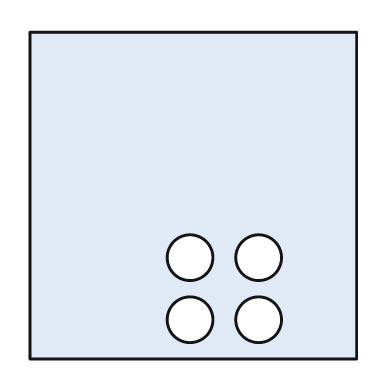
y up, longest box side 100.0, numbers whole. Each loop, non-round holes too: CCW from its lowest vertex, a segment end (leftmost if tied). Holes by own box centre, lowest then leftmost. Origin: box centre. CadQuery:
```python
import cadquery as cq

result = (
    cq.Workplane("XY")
    .moveTo(-50.0, -50.0)
    .lineTo(50.0, -50.0)
    .lineTo(50.0, 50.0)
    .lineTo(-50.0, 50.0)
    .close()
    .moveTo(-1.0, -38.0)
    .circle(7.0)
    .moveTo(20.0, -38.0)
    .circle(7.0)
    .moveTo(-1.0, -19.0)
    .circle(7.0)
    .moveTo(20.0, -19.0)
    .circle(7.0)
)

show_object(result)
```